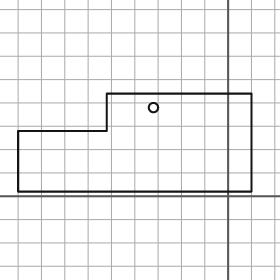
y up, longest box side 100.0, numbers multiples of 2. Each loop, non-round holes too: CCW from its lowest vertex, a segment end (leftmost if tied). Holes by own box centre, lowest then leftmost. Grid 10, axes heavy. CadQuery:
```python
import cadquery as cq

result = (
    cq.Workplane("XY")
    .moveTo(-90.0, 2.0)
    .lineTo(10.0, 2.0)
    .lineTo(10.0, 44.0)
    .lineTo(-52.0, 44.0)
    .lineTo(-52.0, 28.0)
    .lineTo(-90.0, 28.0)
    .close()
    .moveTo(-32.0, 38.0)
    .circle(2.0)
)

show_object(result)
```